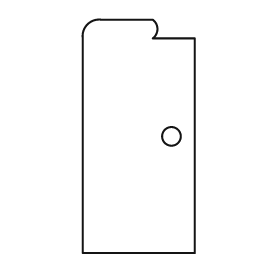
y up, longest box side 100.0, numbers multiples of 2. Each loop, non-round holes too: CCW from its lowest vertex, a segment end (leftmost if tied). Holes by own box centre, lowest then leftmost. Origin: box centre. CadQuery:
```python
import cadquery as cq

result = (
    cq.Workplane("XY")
    .moveTo(-24.0, -50.0)
    .lineTo(24.0, -50.0)
    .lineTo(24.0, 42.0)
    .lineTo(6.0, 42.0)
    .threePointArc((8.0, 46.0), (6.0, 50.0))
    .lineTo(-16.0, 50.0)
    .threePointArc((-22.0, 48.0), (-24.0, 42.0))
    .close()
    .moveTo(14.0, 0.0)
    .circle(4.0)
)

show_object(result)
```